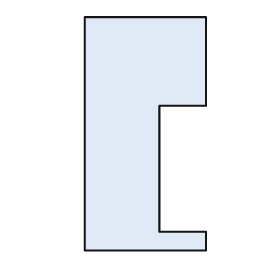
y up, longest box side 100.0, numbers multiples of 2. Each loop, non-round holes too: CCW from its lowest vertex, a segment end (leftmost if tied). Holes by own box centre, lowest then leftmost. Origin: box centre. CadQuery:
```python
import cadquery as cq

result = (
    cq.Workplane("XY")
    .moveTo(-26.0, -50.0)
    .lineTo(26.0, -50.0)
    .lineTo(26.0, -42.0)
    .lineTo(6.0, -42.0)
    .lineTo(6.0, 12.0)
    .lineTo(26.0, 12.0)
    .lineTo(26.0, 50.0)
    .lineTo(-26.0, 50.0)
    .close()
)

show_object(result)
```